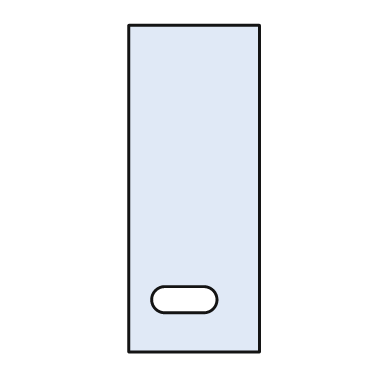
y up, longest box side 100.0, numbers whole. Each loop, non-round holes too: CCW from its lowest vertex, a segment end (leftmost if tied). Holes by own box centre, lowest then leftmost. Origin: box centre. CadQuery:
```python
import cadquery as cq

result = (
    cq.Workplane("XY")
    .moveTo(-20.0, -50.0)
    .lineTo(20.0, -50.0)
    .lineTo(20.0, 50.0)
    .lineTo(-20.0, 50.0)
    .close()
    .moveTo(-9.0, -38.0)
    .lineTo(3.0, -38.0)
    .threePointArc((7.0, -34.0), (3.0, -30.0))
    .lineTo(-9.0, -30.0)
    .threePointArc((-13.0, -34.0), (-9.0, -38.0))
    .close()
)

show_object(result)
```